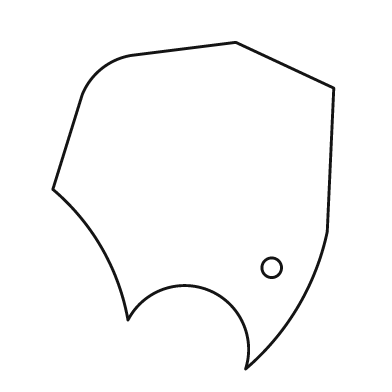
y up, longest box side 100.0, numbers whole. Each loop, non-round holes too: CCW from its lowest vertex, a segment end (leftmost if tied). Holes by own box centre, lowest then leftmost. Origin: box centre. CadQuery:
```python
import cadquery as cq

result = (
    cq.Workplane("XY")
    .moveTo(16.0, -50.0)
    .threePointArc((32.0, -31.0), (41.0, -8.0))
    .lineTo(43.0, 36.0)
    .lineTo(13.0, 50.0)
    .lineTo(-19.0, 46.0)
    .threePointArc((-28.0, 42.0), (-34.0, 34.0))
    .lineTo(-43.0, 5.0)
    .threePointArc((-28.0, -13.0), (-20.0, -35.0))
    .threePointArc((5.0, -26.0), (16.0, -50.0))
    .close()
    .moveTo(24.0, -19.0)
    .circle(3.0)
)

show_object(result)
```